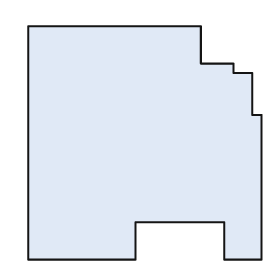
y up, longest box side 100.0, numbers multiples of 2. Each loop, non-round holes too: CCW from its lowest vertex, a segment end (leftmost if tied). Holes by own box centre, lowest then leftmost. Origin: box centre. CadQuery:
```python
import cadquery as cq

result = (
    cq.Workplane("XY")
    .moveTo(-50.0, -50.0)
    .lineTo(-4.0, -50.0)
    .lineTo(-4.0, -34.0)
    .lineTo(34.0, -34.0)
    .lineTo(34.0, -50.0)
    .lineTo(50.0, -50.0)
    .lineTo(50.0, 12.0)
    .lineTo(46.0, 12.0)
    .lineTo(46.0, 30.0)
    .lineTo(38.0, 30.0)
    .lineTo(38.0, 34.0)
    .lineTo(24.0, 34.0)
    .lineTo(24.0, 50.0)
    .lineTo(-50.0, 50.0)
    .close()
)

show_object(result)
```